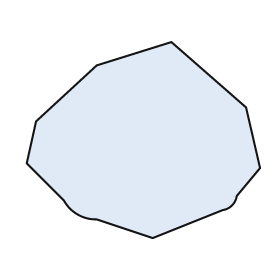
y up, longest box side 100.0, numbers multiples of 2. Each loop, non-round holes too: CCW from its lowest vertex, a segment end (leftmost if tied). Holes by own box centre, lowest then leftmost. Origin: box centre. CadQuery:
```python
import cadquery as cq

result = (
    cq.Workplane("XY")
    .moveTo(4.0, -42.0)
    .lineTo(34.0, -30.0)
    .threePointArc((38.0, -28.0), (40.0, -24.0))
    .lineTo(50.0, -12.0)
    .lineTo(44.0, 14.0)
    .lineTo(12.0, 42.0)
    .lineTo(-20.0, 32.0)
    .lineTo(-46.0, 8.0)
    .lineTo(-50.0, -10.0)
    .lineTo(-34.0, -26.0)
    .threePointArc((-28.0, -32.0), (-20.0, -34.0))
    .close()
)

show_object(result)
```